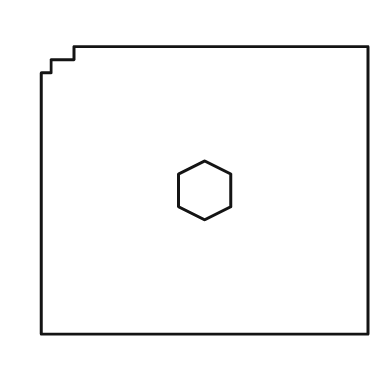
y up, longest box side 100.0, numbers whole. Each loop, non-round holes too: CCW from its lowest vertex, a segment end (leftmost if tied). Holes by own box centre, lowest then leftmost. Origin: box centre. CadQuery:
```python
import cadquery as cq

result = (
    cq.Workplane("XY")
    .moveTo(-50.0, -44.0)
    .lineTo(50.0, -44.0)
    .lineTo(50.0, 44.0)
    .lineTo(-40.0, 44.0)
    .lineTo(-40.0, 40.0)
    .lineTo(-47.0, 40.0)
    .lineTo(-47.0, 36.0)
    .lineTo(-50.0, 36.0)
    .close()
    .moveTo(0.0, -9.0)
    .lineTo(8.0, -5.0)
    .lineTo(8.0, 5.0)
    .lineTo(0.0, 9.0)
    .lineTo(-8.0, 5.0)
    .lineTo(-8.0, -5.0)
    .close()
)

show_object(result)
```